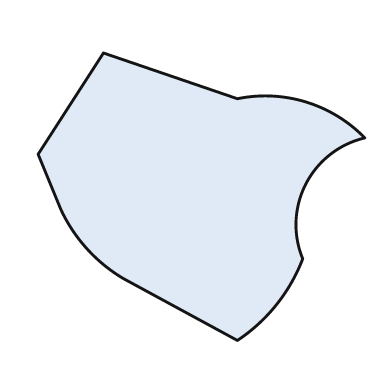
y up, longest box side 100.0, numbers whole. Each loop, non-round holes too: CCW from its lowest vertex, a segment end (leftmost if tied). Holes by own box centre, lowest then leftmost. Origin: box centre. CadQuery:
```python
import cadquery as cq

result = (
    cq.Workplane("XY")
    .moveTo(11.0, -44.0)
    .threePointArc((23.0, -33.0), (31.0, -19.0))
    .threePointArc((32.0, 4.0), (50.0, 18.0))
    .threePointArc((32.0, 29.0), (11.0, 30.0))
    .lineTo(-30.0, 44.0)
    .lineTo(-50.0, 13.0)
    .lineTo(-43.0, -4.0)
    .threePointArc((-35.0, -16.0), (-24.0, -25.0))
    .close()
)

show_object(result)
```